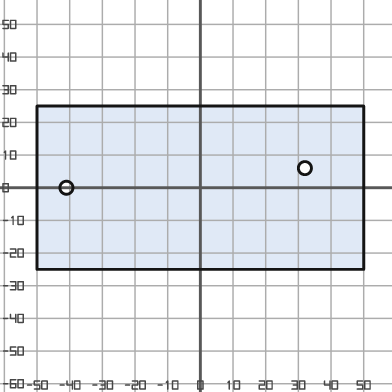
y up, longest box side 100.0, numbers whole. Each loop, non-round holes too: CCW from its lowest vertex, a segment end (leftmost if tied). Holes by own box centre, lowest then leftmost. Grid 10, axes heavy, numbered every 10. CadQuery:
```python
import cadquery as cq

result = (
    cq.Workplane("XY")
    .moveTo(-50.0, -25.0)
    .lineTo(50.0, -25.0)
    .lineTo(50.0, 25.0)
    .lineTo(-50.0, 25.0)
    .close()
    .moveTo(-41.0, 0.0)
    .circle(2.0)
    .moveTo(32.0, 6.0)
    .circle(2.0)
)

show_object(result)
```